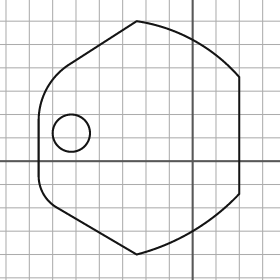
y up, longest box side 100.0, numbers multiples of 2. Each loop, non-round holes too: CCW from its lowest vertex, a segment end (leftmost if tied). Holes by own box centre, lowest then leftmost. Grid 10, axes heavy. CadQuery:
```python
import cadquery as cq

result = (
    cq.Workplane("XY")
    .moveTo(-24.0, -40.0)
    .threePointArc((0.0, -30.0), (20.0, -14.0))
    .lineTo(20.0, 36.0)
    .threePointArc((0.0, 52.0), (-24.0, 60.0))
    .lineTo(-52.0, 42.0)
    .threePointArc((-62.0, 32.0), (-66.0, 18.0))
    .lineTo(-66.0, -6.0)
    .threePointArc((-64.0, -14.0), (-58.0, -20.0))
    .close()
    .moveTo(-52.0, 12.0)
    .circle(8.0)
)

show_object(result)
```